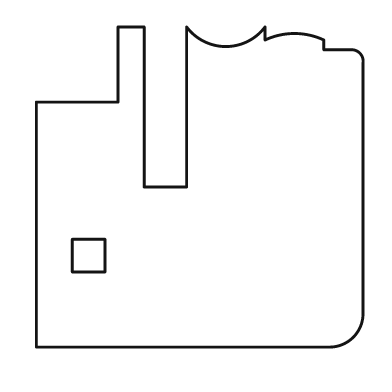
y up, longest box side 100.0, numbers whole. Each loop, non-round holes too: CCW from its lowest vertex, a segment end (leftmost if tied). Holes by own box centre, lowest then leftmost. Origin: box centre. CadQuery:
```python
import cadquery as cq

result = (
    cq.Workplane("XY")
    .moveTo(-50.0, -49.0)
    .lineTo(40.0, -49.0)
    .threePointArc((47.0, -46.0), (50.0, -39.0))
    .lineTo(50.0, 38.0)
    .threePointArc((49.0, 41.0), (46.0, 42.0))
    .lineTo(38.0, 42.0)
    .lineTo(38.0, 45.0)
    .threePointArc((29.0, 47.0), (20.0, 45.0))
    .lineTo(20.0, 49.0)
    .threePointArc((8.0, 43.0), (-4.0, 49.0))
    .lineTo(-4.0, 0.0)
    .lineTo(-17.0, 0.0)
    .lineTo(-17.0, 49.0)
    .lineTo(-25.0, 49.0)
    .lineTo(-25.0, 26.0)
    .lineTo(-50.0, 26.0)
    .close()
    .moveTo(-39.0, -26.0)
    .lineTo(-29.0, -26.0)
    .lineTo(-29.0, -16.0)
    .lineTo(-39.0, -16.0)
    .close()
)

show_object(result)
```